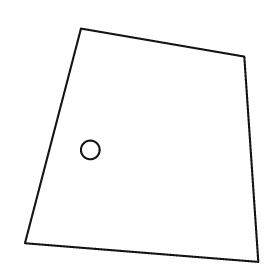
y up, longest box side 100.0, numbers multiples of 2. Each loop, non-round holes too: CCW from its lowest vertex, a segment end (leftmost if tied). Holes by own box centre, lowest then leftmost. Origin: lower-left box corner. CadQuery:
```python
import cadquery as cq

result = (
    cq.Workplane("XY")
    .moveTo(100.0, 0.0)
    .lineTo(94.0, 88.0)
    .lineTo(24.0, 100.0)
    .lineTo(0.0, 8.0)
    .close()
    .moveTo(28.0, 48.0)
    .circle(4.0)
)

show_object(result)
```